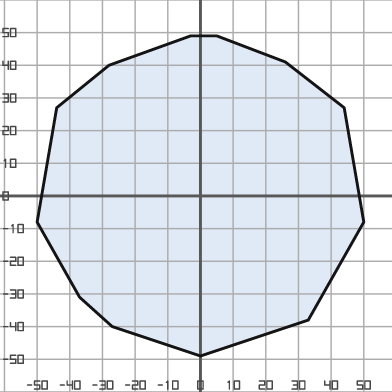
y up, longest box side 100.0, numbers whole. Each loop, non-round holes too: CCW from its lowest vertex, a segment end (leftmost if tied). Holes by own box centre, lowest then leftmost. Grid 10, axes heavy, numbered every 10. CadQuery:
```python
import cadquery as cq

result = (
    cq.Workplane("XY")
    .moveTo(0.0, -49.0)
    .lineTo(33.0, -38.0)
    .lineTo(50.0, -8.0)
    .lineTo(44.0, 27.0)
    .lineTo(26.0, 41.0)
    .lineTo(5.0, 49.0)
    .lineTo(-3.0, 49.0)
    .lineTo(-28.0, 40.0)
    .lineTo(-44.0, 27.0)
    .lineTo(-50.0, -8.0)
    .lineTo(-37.0, -31.0)
    .lineTo(-27.0, -40.0)
    .close()
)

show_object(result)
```